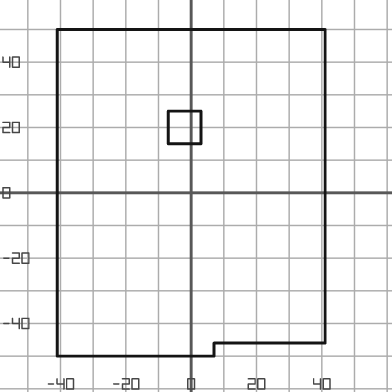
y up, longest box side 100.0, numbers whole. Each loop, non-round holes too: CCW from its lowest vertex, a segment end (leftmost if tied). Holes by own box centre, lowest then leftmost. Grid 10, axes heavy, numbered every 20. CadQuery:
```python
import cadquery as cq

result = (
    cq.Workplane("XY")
    .moveTo(-41.0, -50.0)
    .lineTo(7.0, -50.0)
    .lineTo(7.0, -46.0)
    .lineTo(41.0, -46.0)
    .lineTo(41.0, 50.0)
    .lineTo(-41.0, 50.0)
    .close()
    .moveTo(-7.0, 15.0)
    .lineTo(3.0, 15.0)
    .lineTo(3.0, 25.0)
    .lineTo(-7.0, 25.0)
    .close()
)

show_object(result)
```